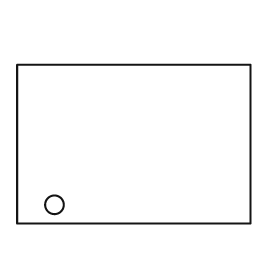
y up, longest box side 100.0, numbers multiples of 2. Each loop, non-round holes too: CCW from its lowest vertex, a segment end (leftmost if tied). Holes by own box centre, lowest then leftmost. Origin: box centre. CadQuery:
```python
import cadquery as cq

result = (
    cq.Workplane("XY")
    .moveTo(-50.0, -34.0)
    .lineTo(50.0, -34.0)
    .lineTo(50.0, 34.0)
    .lineTo(-50.0, 34.0)
    .close()
    .moveTo(-34.0, -26.0)
    .circle(4.0)
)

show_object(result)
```